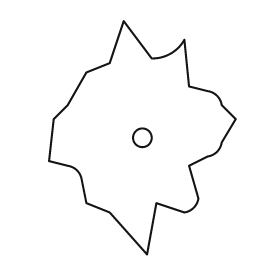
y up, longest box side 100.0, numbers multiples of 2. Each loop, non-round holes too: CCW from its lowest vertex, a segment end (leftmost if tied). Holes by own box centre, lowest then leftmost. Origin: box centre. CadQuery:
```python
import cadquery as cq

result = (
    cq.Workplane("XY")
    .moveTo(2.0, -50.0)
    .lineTo(6.0, -28.0)
    .lineTo(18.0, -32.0)
    .threePointArc((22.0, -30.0), (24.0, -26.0))
    .lineTo(20.0, -12.0)
    .lineTo(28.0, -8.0)
    .threePointArc((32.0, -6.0), (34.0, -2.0))
    .lineTo(40.0, 8.0)
    .lineTo(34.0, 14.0)
    .threePointArc((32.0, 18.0), (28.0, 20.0))
    .lineTo(20.0, 22.0)
    .lineTo(18.0, 42.0)
    .threePointArc((12.0, 36.0), (4.0, 34.0))
    .lineTo(-8.0, 50.0)
    .lineTo(-14.0, 32.0)
    .lineTo(-24.0, 28.0)
    .lineTo(-32.0, 14.0)
    .lineTo(-38.0, 8.0)
    .lineTo(-40.0, -10.0)
    .lineTo(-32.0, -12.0)
    .threePointArc((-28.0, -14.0), (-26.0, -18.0))
    .lineTo(-24.0, -28.0)
    .lineTo(-14.0, -32.0)
    .close()
    .moveTo(0.0, 0.0)
    .circle(4.0)
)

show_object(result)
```